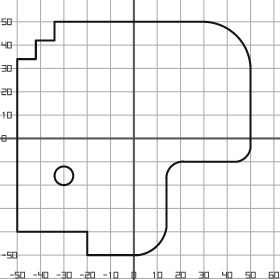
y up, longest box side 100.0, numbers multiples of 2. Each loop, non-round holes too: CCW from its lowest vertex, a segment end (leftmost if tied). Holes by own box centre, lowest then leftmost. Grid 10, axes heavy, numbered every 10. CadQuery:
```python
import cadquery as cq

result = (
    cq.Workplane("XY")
    .moveTo(-20.0, -50.0)
    .lineTo(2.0, -50.0)
    .threePointArc((10.0, -46.0), (14.0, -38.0))
    .lineTo(14.0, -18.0)
    .threePointArc((16.0, -12.0), (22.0, -10.0))
    .lineTo(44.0, -10.0)
    .threePointArc((48.0, -8.0), (50.0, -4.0))
    .lineTo(50.0, 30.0)
    .threePointArc((44.0, 44.0), (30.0, 50.0))
    .lineTo(-34.0, 50.0)
    .lineTo(-34.0, 42.0)
    .lineTo(-42.0, 42.0)
    .lineTo(-42.0, 34.0)
    .lineTo(-50.0, 34.0)
    .lineTo(-50.0, -40.0)
    .lineTo(-20.0, -40.0)
    .close()
    .moveTo(-30.0, -16.0)
    .circle(4.0)
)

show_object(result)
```